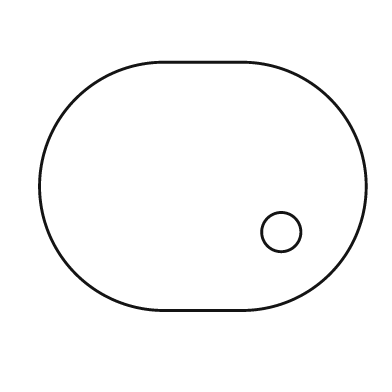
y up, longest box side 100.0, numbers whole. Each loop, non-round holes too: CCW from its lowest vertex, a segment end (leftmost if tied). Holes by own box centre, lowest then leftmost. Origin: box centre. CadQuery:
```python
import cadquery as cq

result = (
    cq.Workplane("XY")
    .moveTo(-12.0, -38.0)
    .lineTo(12.0, -38.0)
    .threePointArc((50.0, 0.0), (12.0, 38.0))
    .lineTo(-12.0, 38.0)
    .threePointArc((-50.0, 0.0), (-12.0, -38.0))
    .close()
    .moveTo(24.0, -14.0)
    .circle(6.0)
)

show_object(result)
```